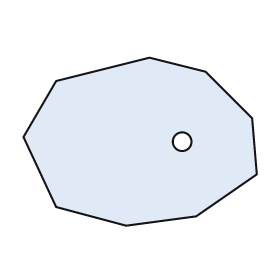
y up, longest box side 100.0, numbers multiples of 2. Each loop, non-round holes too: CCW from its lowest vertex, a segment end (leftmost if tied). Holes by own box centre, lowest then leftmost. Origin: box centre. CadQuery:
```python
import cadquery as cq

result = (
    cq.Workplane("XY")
    .moveTo(-6.0, -36.0)
    .lineTo(24.0, -32.0)
    .lineTo(50.0, -14.0)
    .lineTo(48.0, 10.0)
    .lineTo(28.0, 30.0)
    .lineTo(4.0, 36.0)
    .lineTo(-36.0, 26.0)
    .lineTo(-50.0, 2.0)
    .lineTo(-36.0, -28.0)
    .close()
    .moveTo(18.0, 0.0)
    .circle(4.0)
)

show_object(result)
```